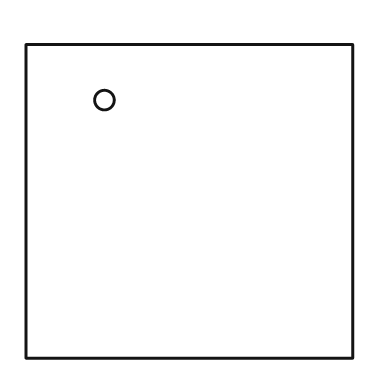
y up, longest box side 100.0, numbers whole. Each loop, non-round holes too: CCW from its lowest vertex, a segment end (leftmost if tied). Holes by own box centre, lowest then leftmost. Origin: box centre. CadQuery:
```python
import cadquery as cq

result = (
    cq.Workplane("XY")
    .moveTo(-50.0, -48.0)
    .lineTo(50.0, -48.0)
    .lineTo(50.0, 48.0)
    .lineTo(-50.0, 48.0)
    .close()
    .moveTo(-26.0, 31.0)
    .circle(3.0)
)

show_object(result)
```